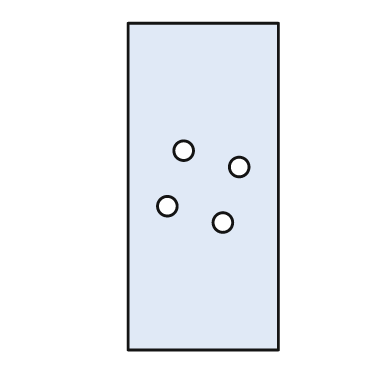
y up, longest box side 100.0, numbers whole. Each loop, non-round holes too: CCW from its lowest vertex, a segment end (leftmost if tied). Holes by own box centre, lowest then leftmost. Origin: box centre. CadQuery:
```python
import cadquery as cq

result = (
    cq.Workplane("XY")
    .moveTo(-23.0, -50.0)
    .lineTo(23.0, -50.0)
    .lineTo(23.0, 50.0)
    .lineTo(-23.0, 50.0)
    .close()
    .moveTo(6.0, -11.0)
    .circle(3.0)
    .moveTo(-11.0, -6.0)
    .circle(3.0)
    .moveTo(11.0, 6.0)
    .circle(3.0)
    .moveTo(-6.0, 11.0)
    .circle(3.0)
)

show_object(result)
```